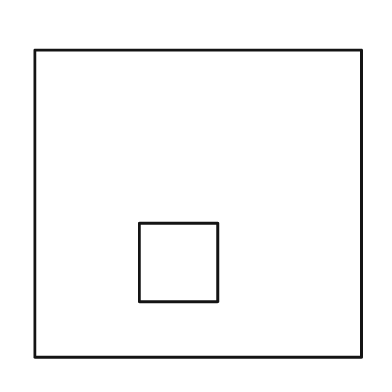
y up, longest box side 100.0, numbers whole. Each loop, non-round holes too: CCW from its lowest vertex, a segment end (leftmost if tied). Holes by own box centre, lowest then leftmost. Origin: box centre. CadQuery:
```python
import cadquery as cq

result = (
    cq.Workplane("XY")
    .moveTo(-50.0, -47.0)
    .lineTo(50.0, -47.0)
    .lineTo(50.0, 47.0)
    .lineTo(-50.0, 47.0)
    .close()
    .moveTo(-18.0, -30.0)
    .lineTo(6.0, -30.0)
    .lineTo(6.0, -6.0)
    .lineTo(-18.0, -6.0)
    .close()
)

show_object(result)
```